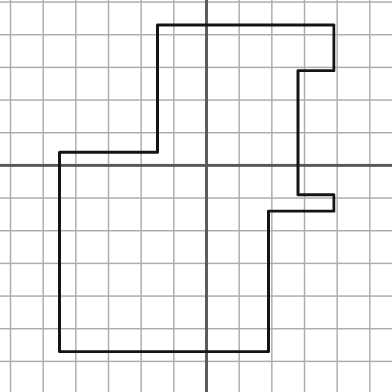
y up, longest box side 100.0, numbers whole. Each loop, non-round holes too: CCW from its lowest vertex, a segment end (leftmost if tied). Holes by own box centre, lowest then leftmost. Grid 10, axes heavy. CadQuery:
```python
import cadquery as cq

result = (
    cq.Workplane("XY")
    .moveTo(-45.0, -57.0)
    .lineTo(19.0, -57.0)
    .lineTo(19.0, -14.0)
    .lineTo(39.0, -14.0)
    .lineTo(39.0, -9.0)
    .lineTo(28.0, -9.0)
    .lineTo(28.0, 29.0)
    .lineTo(39.0, 29.0)
    .lineTo(39.0, 43.0)
    .lineTo(-15.0, 43.0)
    .lineTo(-15.0, 4.0)
    .lineTo(-45.0, 4.0)
    .close()
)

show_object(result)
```